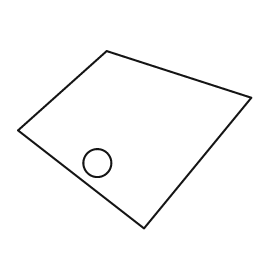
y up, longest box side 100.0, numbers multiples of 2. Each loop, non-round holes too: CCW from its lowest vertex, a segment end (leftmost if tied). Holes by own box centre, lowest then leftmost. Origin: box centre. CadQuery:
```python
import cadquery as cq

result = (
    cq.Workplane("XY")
    .moveTo(4.0, -38.0)
    .lineTo(50.0, 18.0)
    .lineTo(-12.0, 38.0)
    .lineTo(-50.0, 4.0)
    .close()
    .moveTo(-16.0, -10.0)
    .circle(6.0)
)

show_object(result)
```